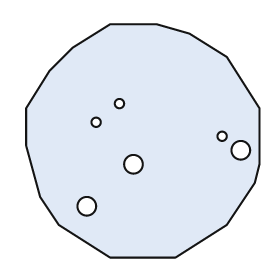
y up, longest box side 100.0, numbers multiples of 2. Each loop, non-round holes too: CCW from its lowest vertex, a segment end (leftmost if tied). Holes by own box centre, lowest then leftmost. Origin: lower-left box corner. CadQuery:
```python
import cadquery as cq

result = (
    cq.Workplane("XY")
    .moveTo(36.0, 0.0)
    .lineTo(64.0, 0.0)
    .lineTo(86.0, 14.0)
    .lineTo(98.0, 32.0)
    .lineTo(100.0, 40.0)
    .lineTo(100.0, 64.0)
    .lineTo(86.0, 86.0)
    .lineTo(70.0, 96.0)
    .lineTo(56.0, 100.0)
    .lineTo(36.0, 100.0)
    .lineTo(20.0, 90.0)
    .lineTo(10.0, 80.0)
    .lineTo(0.0, 64.0)
    .lineTo(0.0, 48.0)
    .lineTo(6.0, 26.0)
    .lineTo(14.0, 14.0)
    .close()
    .moveTo(26.0, 22.0)
    .circle(4.0)
    .moveTo(46.0, 40.0)
    .circle(4.0)
    .moveTo(92.0, 46.0)
    .circle(4.0)
    .moveTo(84.0, 52.0)
    .circle(2.0)
    .moveTo(30.0, 58.0)
    .circle(2.0)
    .moveTo(40.0, 66.0)
    .circle(2.0)
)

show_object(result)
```